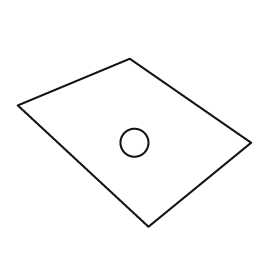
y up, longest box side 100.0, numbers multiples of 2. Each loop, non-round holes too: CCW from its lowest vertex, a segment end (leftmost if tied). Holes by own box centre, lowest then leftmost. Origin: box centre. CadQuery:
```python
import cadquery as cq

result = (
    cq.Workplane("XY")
    .moveTo(6.0, -36.0)
    .lineTo(50.0, 0.0)
    .lineTo(-2.0, 36.0)
    .lineTo(-50.0, 16.0)
    .close()
    .moveTo(0.0, 0.0)
    .circle(6.0)
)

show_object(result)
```